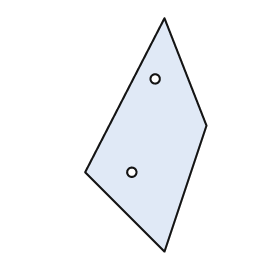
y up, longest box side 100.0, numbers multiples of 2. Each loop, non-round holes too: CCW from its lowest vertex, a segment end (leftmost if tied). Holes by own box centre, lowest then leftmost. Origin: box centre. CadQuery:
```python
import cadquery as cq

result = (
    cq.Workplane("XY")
    .moveTo(8.0, -50.0)
    .lineTo(26.0, 4.0)
    .lineTo(8.0, 50.0)
    .lineTo(-26.0, -16.0)
    .close()
    .moveTo(-6.0, -16.0)
    .circle(2.0)
    .moveTo(4.0, 24.0)
    .circle(2.0)
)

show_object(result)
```